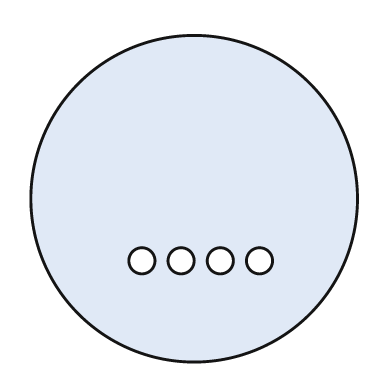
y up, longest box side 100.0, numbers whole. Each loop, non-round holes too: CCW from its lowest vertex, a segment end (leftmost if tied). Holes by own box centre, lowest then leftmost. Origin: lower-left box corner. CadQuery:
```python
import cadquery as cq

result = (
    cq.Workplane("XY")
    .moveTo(50.0, 50.0)
    .circle(50.0)
    .moveTo(34.0, 31.0)
    .circle(4.0)
    .moveTo(46.0, 31.0)
    .circle(4.0)
    .moveTo(58.0, 31.0)
    .circle(4.0)
    .moveTo(70.0, 31.0)
    .circle(4.0)
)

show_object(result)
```